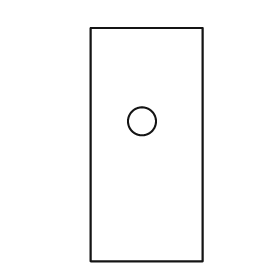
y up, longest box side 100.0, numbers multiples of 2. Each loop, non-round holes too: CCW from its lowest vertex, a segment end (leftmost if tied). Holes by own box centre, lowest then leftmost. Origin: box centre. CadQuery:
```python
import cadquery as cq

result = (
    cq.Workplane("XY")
    .moveTo(-24.0, -50.0)
    .lineTo(24.0, -50.0)
    .lineTo(24.0, 50.0)
    .lineTo(-24.0, 50.0)
    .close()
    .moveTo(-2.0, 10.0)
    .circle(6.0)
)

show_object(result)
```